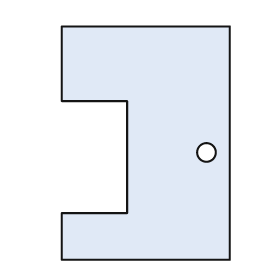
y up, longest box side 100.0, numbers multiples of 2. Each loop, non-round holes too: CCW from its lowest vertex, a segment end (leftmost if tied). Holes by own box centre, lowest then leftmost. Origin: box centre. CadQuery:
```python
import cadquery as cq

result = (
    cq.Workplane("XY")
    .moveTo(-36.0, -50.0)
    .lineTo(36.0, -50.0)
    .lineTo(36.0, 50.0)
    .lineTo(-36.0, 50.0)
    .lineTo(-36.0, 18.0)
    .lineTo(-8.0, 18.0)
    .lineTo(-8.0, -30.0)
    .lineTo(-36.0, -30.0)
    .close()
    .moveTo(26.0, -4.0)
    .circle(4.0)
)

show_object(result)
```